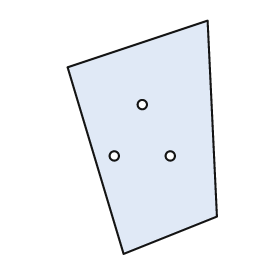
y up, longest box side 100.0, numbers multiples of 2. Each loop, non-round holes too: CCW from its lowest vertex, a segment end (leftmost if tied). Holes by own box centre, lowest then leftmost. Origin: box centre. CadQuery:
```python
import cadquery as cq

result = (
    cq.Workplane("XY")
    .moveTo(-8.0, -50.0)
    .lineTo(32.0, -34.0)
    .lineTo(28.0, 50.0)
    .lineTo(-32.0, 30.0)
    .close()
    .moveTo(-12.0, -8.0)
    .circle(2.0)
    .moveTo(12.0, -8.0)
    .circle(2.0)
    .moveTo(0.0, 14.0)
    .circle(2.0)
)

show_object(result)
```